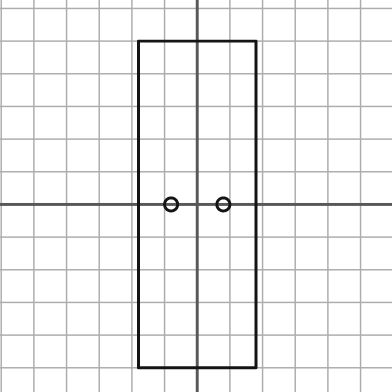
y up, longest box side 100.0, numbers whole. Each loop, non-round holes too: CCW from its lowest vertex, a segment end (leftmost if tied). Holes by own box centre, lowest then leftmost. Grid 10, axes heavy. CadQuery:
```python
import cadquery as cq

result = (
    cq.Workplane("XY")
    .moveTo(-18.0, -50.0)
    .lineTo(18.0, -50.0)
    .lineTo(18.0, 50.0)
    .lineTo(-18.0, 50.0)
    .close()
    .moveTo(-8.0, 0.0)
    .circle(2.0)
    .moveTo(8.0, 0.0)
    .circle(2.0)
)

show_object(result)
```